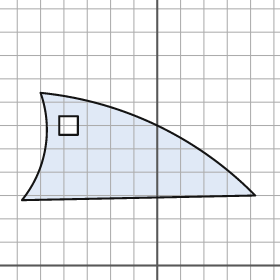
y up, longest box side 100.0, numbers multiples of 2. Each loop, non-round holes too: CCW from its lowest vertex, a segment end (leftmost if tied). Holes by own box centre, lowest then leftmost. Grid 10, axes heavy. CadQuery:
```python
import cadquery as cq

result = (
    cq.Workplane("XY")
    .moveTo(-58.0, 28.0)
    .lineTo(42.0, 30.0)
    .threePointArc((0.0, 60.0), (-50.0, 74.0))
    .threePointArc((-48.0, 50.0), (-58.0, 28.0))
    .close()
    .moveTo(-42.0, 56.0)
    .lineTo(-34.0, 56.0)
    .lineTo(-34.0, 64.0)
    .lineTo(-42.0, 64.0)
    .close()
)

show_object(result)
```